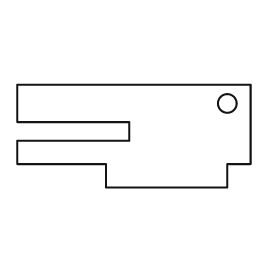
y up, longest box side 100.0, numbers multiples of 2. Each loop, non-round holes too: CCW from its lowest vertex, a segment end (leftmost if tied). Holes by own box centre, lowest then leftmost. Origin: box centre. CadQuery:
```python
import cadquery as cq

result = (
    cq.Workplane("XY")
    .moveTo(-12.0, -22.0)
    .lineTo(40.0, -22.0)
    .lineTo(40.0, -12.0)
    .lineTo(50.0, -12.0)
    .lineTo(50.0, 22.0)
    .lineTo(-50.0, 22.0)
    .lineTo(-50.0, 6.0)
    .lineTo(-2.0, 6.0)
    .lineTo(-2.0, -2.0)
    .lineTo(-50.0, -2.0)
    .lineTo(-50.0, -12.0)
    .lineTo(-12.0, -12.0)
    .close()
    .moveTo(40.0, 14.0)
    .circle(4.0)
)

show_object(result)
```